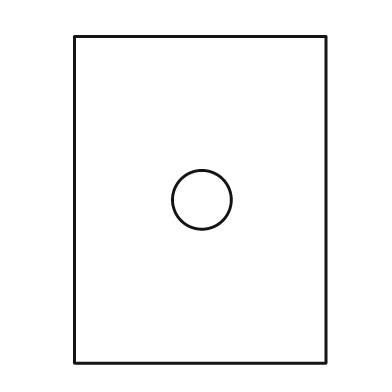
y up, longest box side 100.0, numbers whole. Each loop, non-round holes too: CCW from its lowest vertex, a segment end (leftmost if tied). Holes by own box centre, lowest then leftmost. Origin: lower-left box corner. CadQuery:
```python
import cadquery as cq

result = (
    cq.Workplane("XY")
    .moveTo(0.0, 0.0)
    .lineTo(77.0, 0.0)
    .lineTo(77.0, 100.0)
    .lineTo(0.0, 100.0)
    .close()
    .moveTo(39.0, 50.0)
    .circle(9.0)
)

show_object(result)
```